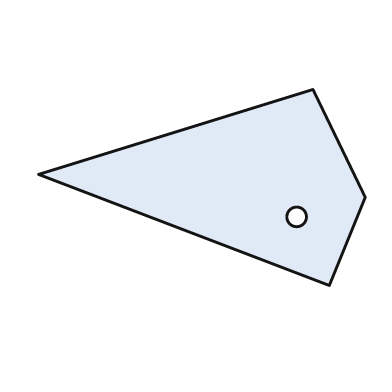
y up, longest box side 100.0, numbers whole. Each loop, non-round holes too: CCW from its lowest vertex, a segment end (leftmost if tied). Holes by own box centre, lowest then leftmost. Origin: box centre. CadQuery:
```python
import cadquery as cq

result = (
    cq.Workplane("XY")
    .moveTo(39.0, -30.0)
    .lineTo(50.0, -3.0)
    .lineTo(34.0, 30.0)
    .lineTo(-50.0, 4.0)
    .close()
    .moveTo(29.0, -9.0)
    .circle(3.0)
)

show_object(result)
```